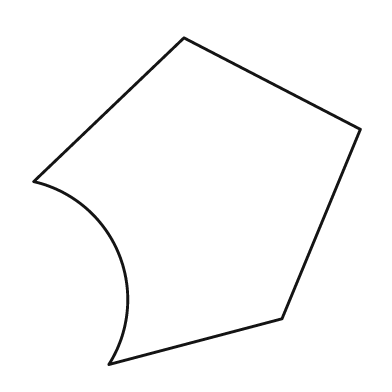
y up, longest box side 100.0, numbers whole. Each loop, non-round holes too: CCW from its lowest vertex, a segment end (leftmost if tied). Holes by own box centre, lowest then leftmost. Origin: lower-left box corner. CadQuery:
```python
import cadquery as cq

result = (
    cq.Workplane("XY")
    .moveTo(23.0, 0.0)
    .lineTo(76.0, 14.0)
    .lineTo(100.0, 72.0)
    .lineTo(46.0, 100.0)
    .lineTo(0.0, 56.0)
    .threePointArc((26.0, 34.0), (23.0, 0.0))
    .close()
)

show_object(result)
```